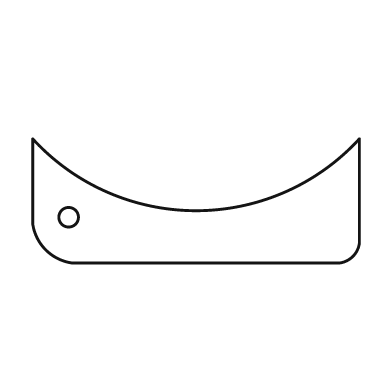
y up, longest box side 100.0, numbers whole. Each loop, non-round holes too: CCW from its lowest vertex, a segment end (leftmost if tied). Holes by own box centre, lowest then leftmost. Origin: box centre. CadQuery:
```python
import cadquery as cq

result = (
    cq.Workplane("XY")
    .moveTo(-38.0, -19.0)
    .lineTo(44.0, -19.0)
    .threePointArc((48.0, -17.0), (50.0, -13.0))
    .lineTo(50.0, 19.0)
    .threePointArc((0.0, -3.0), (-50.0, 19.0))
    .lineTo(-50.0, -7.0)
    .threePointArc((-46.0, -15.0), (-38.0, -19.0))
    .close()
    .moveTo(-39.0, -5.0)
    .circle(3.0)
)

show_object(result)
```